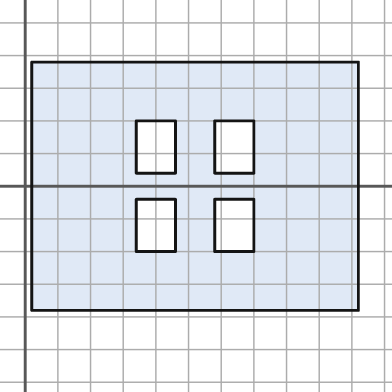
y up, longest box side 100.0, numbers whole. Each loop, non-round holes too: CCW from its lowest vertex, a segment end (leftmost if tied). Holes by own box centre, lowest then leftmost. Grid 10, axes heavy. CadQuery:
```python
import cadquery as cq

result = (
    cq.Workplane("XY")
    .moveTo(2.0, -38.0)
    .lineTo(102.0, -38.0)
    .lineTo(102.0, 38.0)
    .lineTo(2.0, 38.0)
    .close()
    .moveTo(34.0, -20.0)
    .lineTo(46.0, -20.0)
    .lineTo(46.0, -4.0)
    .lineTo(34.0, -4.0)
    .close()
    .moveTo(58.0, -20.0)
    .lineTo(70.0, -20.0)
    .lineTo(70.0, -4.0)
    .lineTo(58.0, -4.0)
    .close()
    .moveTo(34.0, 4.0)
    .lineTo(46.0, 4.0)
    .lineTo(46.0, 20.0)
    .lineTo(34.0, 20.0)
    .close()
    .moveTo(58.0, 4.0)
    .lineTo(70.0, 4.0)
    .lineTo(70.0, 20.0)
    .lineTo(58.0, 20.0)
    .close()
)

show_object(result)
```